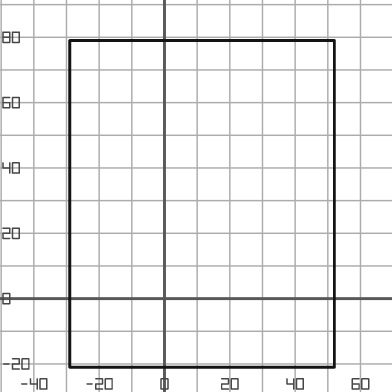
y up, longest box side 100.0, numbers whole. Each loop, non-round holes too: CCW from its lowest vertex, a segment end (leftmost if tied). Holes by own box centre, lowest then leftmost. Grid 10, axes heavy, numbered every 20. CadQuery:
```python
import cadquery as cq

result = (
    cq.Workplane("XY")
    .moveTo(-29.0, -21.0)
    .lineTo(52.0, -21.0)
    .lineTo(52.0, 79.0)
    .lineTo(-29.0, 79.0)
    .close()
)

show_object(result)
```